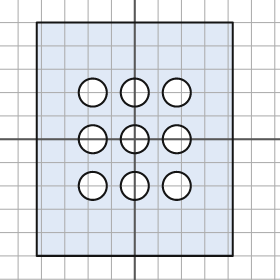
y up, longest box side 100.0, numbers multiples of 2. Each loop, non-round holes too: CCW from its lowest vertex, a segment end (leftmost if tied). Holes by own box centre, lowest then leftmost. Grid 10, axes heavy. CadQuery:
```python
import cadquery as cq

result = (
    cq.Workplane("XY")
    .moveTo(-42.0, -50.0)
    .lineTo(42.0, -50.0)
    .lineTo(42.0, 50.0)
    .lineTo(-42.0, 50.0)
    .close()
    .moveTo(-18.0, -20.0)
    .circle(6.0)
    .moveTo(0.0, -20.0)
    .circle(6.0)
    .moveTo(18.0, -20.0)
    .circle(6.0)
    .moveTo(-18.0, 0.0)
    .circle(6.0)
    .moveTo(0.0, 0.0)
    .circle(6.0)
    .moveTo(18.0, 0.0)
    .circle(6.0)
    .moveTo(-18.0, 20.0)
    .circle(6.0)
    .moveTo(0.0, 20.0)
    .circle(6.0)
    .moveTo(18.0, 20.0)
    .circle(6.0)
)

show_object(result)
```